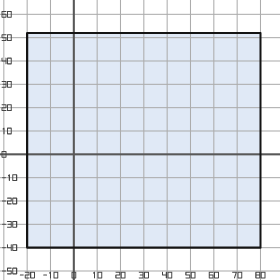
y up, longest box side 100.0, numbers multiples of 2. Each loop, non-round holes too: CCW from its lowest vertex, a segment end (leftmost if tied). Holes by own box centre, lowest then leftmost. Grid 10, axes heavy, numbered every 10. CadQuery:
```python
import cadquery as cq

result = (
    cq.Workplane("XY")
    .moveTo(-20.0, -40.0)
    .lineTo(80.0, -40.0)
    .lineTo(80.0, 52.0)
    .lineTo(-20.0, 52.0)
    .close()
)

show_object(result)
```